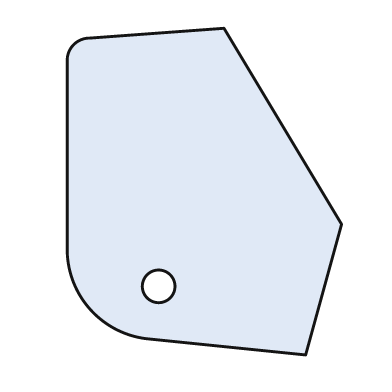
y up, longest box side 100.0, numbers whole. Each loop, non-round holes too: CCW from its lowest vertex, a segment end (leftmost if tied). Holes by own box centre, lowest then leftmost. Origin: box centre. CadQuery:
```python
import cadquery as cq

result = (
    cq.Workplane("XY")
    .moveTo(31.0, -50.0)
    .lineTo(42.0, -10.0)
    .lineTo(6.0, 50.0)
    .lineTo(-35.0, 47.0)
    .threePointArc((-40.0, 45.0), (-42.0, 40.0))
    .lineTo(-42.0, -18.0)
    .threePointArc((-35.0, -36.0), (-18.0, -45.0))
    .close()
    .moveTo(-14.0, -29.0)
    .circle(5.0)
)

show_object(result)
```